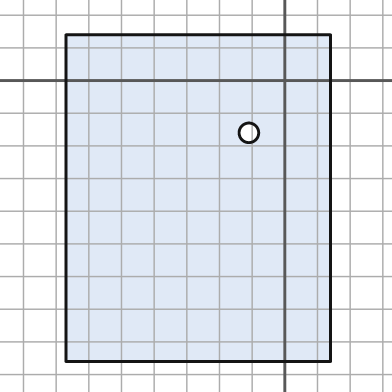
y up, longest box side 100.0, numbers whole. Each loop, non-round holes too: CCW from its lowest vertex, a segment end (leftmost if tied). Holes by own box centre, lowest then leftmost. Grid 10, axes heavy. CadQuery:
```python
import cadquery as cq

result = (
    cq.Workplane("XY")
    .moveTo(-67.0, -86.0)
    .lineTo(14.0, -86.0)
    .lineTo(14.0, 14.0)
    .lineTo(-67.0, 14.0)
    .close()
    .moveTo(-11.0, -16.0)
    .circle(3.0)
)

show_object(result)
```